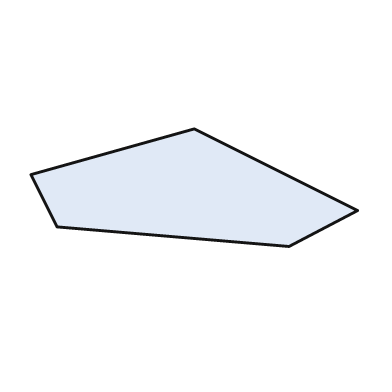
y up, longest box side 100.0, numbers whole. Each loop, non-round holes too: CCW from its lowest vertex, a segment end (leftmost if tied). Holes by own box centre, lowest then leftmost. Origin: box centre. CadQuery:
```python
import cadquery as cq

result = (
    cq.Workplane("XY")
    .moveTo(29.0, -18.0)
    .lineTo(50.0, -7.0)
    .lineTo(0.0, 18.0)
    .lineTo(-50.0, 4.0)
    .lineTo(-42.0, -12.0)
    .close()
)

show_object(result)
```